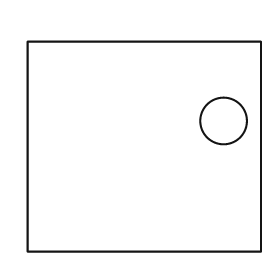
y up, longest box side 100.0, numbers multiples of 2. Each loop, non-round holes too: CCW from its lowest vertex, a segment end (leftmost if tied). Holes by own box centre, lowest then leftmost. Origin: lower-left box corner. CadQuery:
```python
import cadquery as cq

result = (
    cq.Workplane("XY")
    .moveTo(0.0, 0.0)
    .lineTo(100.0, 0.0)
    .lineTo(100.0, 90.0)
    .lineTo(0.0, 90.0)
    .close()
    .moveTo(84.0, 56.0)
    .circle(10.0)
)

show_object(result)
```